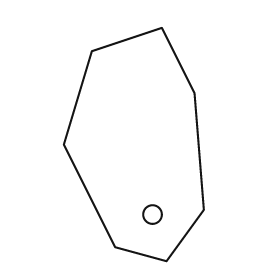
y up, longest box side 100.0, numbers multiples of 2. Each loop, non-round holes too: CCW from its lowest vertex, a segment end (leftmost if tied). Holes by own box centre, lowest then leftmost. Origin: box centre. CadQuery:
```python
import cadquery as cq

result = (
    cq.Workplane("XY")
    .moveTo(14.0, -50.0)
    .lineTo(30.0, -28.0)
    .lineTo(26.0, 22.0)
    .lineTo(12.0, 50.0)
    .lineTo(-18.0, 40.0)
    .lineTo(-30.0, 0.0)
    .lineTo(-8.0, -44.0)
    .close()
    .moveTo(8.0, -30.0)
    .circle(4.0)
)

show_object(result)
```